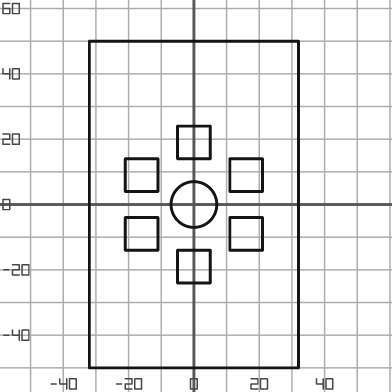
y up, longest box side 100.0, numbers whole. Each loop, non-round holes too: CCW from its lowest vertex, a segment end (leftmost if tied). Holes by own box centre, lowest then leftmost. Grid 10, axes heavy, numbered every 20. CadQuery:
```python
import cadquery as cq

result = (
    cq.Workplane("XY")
    .moveTo(-32.0, -50.0)
    .lineTo(32.0, -50.0)
    .lineTo(32.0, 50.0)
    .lineTo(-32.0, 50.0)
    .close()
    .moveTo(-5.0, -24.0)
    .lineTo(5.0, -24.0)
    .lineTo(5.0, -14.0)
    .lineTo(-5.0, -14.0)
    .close()
    .moveTo(-21.0, -14.0)
    .lineTo(-11.0, -14.0)
    .lineTo(-11.0, -4.0)
    .lineTo(-21.0, -4.0)
    .close()
    .moveTo(11.0, -14.0)
    .lineTo(21.0, -14.0)
    .lineTo(21.0, -4.0)
    .lineTo(11.0, -4.0)
    .close()
    .moveTo(0.0, 0.0)
    .circle(7.0)
    .moveTo(-21.0, 4.0)
    .lineTo(-11.0, 4.0)
    .lineTo(-11.0, 14.0)
    .lineTo(-21.0, 14.0)
    .close()
    .moveTo(11.0, 4.0)
    .lineTo(21.0, 4.0)
    .lineTo(21.0, 14.0)
    .lineTo(11.0, 14.0)
    .close()
    .moveTo(-5.0, 14.0)
    .lineTo(5.0, 14.0)
    .lineTo(5.0, 24.0)
    .lineTo(-5.0, 24.0)
    .close()
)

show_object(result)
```